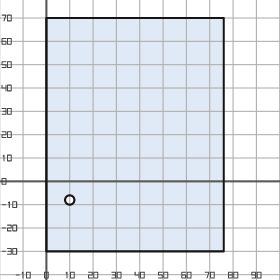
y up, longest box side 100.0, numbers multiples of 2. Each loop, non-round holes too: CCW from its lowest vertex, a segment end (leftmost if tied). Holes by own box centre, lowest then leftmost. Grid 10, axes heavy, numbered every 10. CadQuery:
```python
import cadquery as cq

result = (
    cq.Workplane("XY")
    .moveTo(0.0, -30.0)
    .lineTo(76.0, -30.0)
    .lineTo(76.0, 70.0)
    .lineTo(0.0, 70.0)
    .close()
    .moveTo(10.0, -8.0)
    .circle(2.0)
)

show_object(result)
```